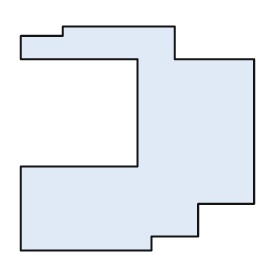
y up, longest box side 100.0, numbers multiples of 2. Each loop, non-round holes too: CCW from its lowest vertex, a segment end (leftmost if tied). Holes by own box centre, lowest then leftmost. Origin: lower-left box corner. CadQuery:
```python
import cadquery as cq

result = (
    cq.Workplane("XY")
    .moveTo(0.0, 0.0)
    .lineTo(56.0, 0.0)
    .lineTo(56.0, 6.0)
    .lineTo(76.0, 6.0)
    .lineTo(76.0, 20.0)
    .lineTo(100.0, 20.0)
    .lineTo(100.0, 82.0)
    .lineTo(66.0, 82.0)
    .lineTo(66.0, 96.0)
    .lineTo(18.0, 96.0)
    .lineTo(18.0, 92.0)
    .lineTo(0.0, 92.0)
    .lineTo(0.0, 82.0)
    .lineTo(50.0, 82.0)
    .lineTo(50.0, 36.0)
    .lineTo(0.0, 36.0)
    .close()
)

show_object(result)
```